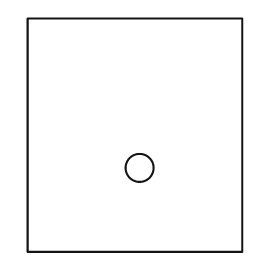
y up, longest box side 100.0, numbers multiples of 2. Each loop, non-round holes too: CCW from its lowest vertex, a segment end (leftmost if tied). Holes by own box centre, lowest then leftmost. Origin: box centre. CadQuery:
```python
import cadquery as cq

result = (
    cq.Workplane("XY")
    .moveTo(-46.0, -50.0)
    .lineTo(46.0, -50.0)
    .lineTo(46.0, 50.0)
    .lineTo(-46.0, 50.0)
    .close()
    .moveTo(2.0, -14.0)
    .circle(6.0)
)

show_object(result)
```